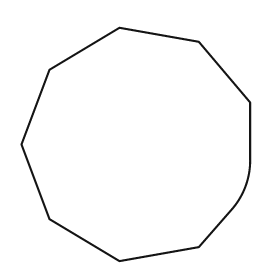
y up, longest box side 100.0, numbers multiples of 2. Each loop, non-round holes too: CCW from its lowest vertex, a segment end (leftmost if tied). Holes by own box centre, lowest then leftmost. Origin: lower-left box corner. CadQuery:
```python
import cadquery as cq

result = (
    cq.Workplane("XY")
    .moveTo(42.0, 0.0)
    .lineTo(76.0, 6.0)
    .lineTo(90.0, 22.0)
    .threePointArc((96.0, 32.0), (98.0, 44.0))
    .lineTo(98.0, 68.0)
    .lineTo(76.0, 94.0)
    .lineTo(42.0, 100.0)
    .lineTo(12.0, 82.0)
    .lineTo(0.0, 50.0)
    .lineTo(12.0, 18.0)
    .close()
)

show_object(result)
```